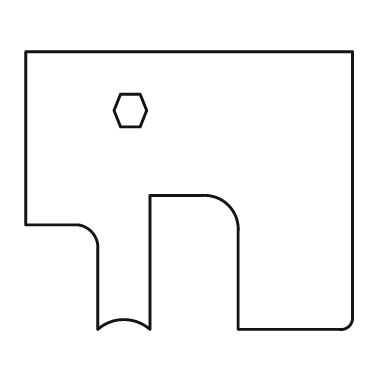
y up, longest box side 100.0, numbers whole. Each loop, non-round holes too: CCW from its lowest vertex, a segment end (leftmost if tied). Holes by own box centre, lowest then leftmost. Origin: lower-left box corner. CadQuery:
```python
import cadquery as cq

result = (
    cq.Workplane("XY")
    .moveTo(22.0, 0.0)
    .threePointArc((30.0, 3.0), (38.0, 0.0))
    .lineTo(38.0, 41.0)
    .lineTo(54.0, 41.0)
    .threePointArc((62.0, 38.0), (65.0, 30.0))
    .lineTo(65.0, 0.0)
    .lineTo(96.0, 0.0)
    .threePointArc((99.0, 1.0), (100.0, 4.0))
    .lineTo(100.0, 85.0)
    .lineTo(0.0, 85.0)
    .lineTo(0.0, 32.0)
    .lineTo(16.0, 32.0)
    .threePointArc((20.0, 30.0), (22.0, 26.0))
    .close()
    .moveTo(29.0, 62.0)
    .lineTo(35.0, 62.0)
    .lineTo(37.0, 67.0)
    .lineTo(35.0, 72.0)
    .lineTo(29.0, 72.0)
    .lineTo(27.0, 67.0)
    .close()
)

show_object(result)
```